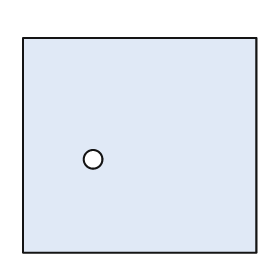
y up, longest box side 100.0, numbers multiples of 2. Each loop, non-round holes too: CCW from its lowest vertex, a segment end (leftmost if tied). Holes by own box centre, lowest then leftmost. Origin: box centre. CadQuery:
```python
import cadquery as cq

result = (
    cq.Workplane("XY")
    .moveTo(-50.0, -46.0)
    .lineTo(50.0, -46.0)
    .lineTo(50.0, 46.0)
    .lineTo(-50.0, 46.0)
    .close()
    .moveTo(-20.0, -6.0)
    .circle(4.0)
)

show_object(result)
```